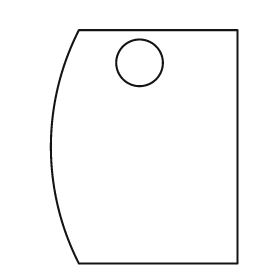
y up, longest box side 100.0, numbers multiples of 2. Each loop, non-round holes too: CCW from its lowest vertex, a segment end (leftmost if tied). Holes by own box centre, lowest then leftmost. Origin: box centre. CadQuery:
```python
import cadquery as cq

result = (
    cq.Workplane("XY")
    .moveTo(-28.0, -50.0)
    .lineTo(40.0, -50.0)
    .lineTo(40.0, 50.0)
    .lineTo(-28.0, 50.0)
    .threePointArc((-40.0, 0.0), (-28.0, -50.0))
    .close()
    .moveTo(-2.0, 36.0)
    .circle(10.0)
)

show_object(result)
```